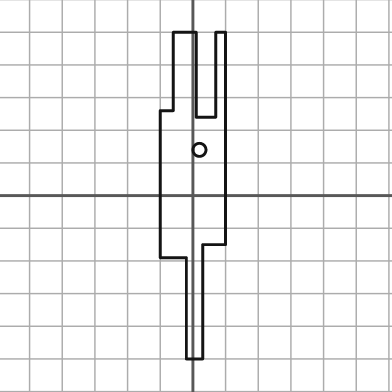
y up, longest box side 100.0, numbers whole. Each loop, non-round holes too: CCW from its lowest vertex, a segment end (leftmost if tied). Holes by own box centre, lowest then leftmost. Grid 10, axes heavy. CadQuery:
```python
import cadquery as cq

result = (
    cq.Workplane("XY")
    .moveTo(-2.0, -50.0)
    .lineTo(3.0, -50.0)
    .lineTo(3.0, -15.0)
    .lineTo(10.0, -15.0)
    .lineTo(10.0, 50.0)
    .lineTo(7.0, 50.0)
    .lineTo(7.0, 24.0)
    .lineTo(1.0, 24.0)
    .lineTo(1.0, 50.0)
    .lineTo(-6.0, 50.0)
    .lineTo(-6.0, 26.0)
    .lineTo(-10.0, 26.0)
    .lineTo(-10.0, -19.0)
    .lineTo(-2.0, -19.0)
    .close()
    .moveTo(2.0, 14.0)
    .circle(2.0)
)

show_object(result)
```